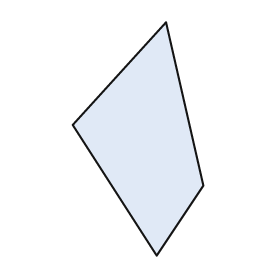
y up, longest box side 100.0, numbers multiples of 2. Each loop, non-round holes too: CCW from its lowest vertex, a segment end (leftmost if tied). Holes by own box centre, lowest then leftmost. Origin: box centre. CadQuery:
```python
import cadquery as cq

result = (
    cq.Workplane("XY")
    .moveTo(8.0, -50.0)
    .lineTo(28.0, -20.0)
    .lineTo(12.0, 50.0)
    .lineTo(-28.0, 6.0)
    .close()
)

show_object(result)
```